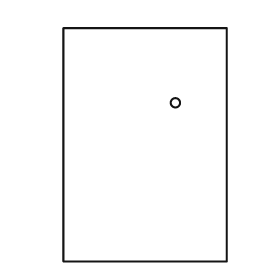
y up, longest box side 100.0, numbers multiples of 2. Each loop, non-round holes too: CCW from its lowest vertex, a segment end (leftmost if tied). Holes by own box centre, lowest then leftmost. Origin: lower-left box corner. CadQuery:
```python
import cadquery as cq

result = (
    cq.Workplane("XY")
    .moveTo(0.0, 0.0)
    .lineTo(70.0, 0.0)
    .lineTo(70.0, 100.0)
    .lineTo(0.0, 100.0)
    .close()
    .moveTo(48.0, 68.0)
    .circle(2.0)
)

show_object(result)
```